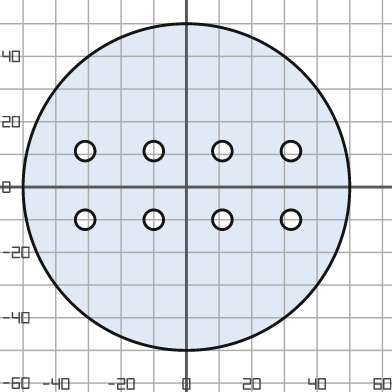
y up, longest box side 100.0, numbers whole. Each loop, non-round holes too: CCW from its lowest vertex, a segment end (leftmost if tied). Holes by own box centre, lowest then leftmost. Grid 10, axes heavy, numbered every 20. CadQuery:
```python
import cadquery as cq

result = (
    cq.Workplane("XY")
    .moveTo(0.0, 0.0)
    .circle(50.0)
    .moveTo(-31.0, -10.0)
    .circle(3.0)
    .moveTo(-10.0, -10.0)
    .circle(3.0)
    .moveTo(11.0, -10.0)
    .circle(3.0)
    .moveTo(32.0, -10.0)
    .circle(3.0)
    .moveTo(-31.0, 11.0)
    .circle(3.0)
    .moveTo(-10.0, 11.0)
    .circle(3.0)
    .moveTo(11.0, 11.0)
    .circle(3.0)
    .moveTo(32.0, 11.0)
    .circle(3.0)
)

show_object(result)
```